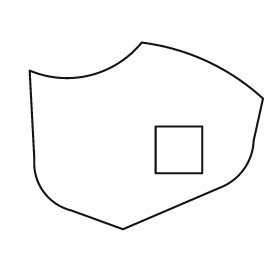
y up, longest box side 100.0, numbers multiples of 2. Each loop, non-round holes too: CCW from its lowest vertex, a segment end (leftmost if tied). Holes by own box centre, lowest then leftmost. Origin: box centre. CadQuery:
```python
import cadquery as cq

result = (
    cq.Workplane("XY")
    .moveTo(-10.0, -40.0)
    .lineTo(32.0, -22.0)
    .threePointArc((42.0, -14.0), (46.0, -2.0))
    .lineTo(50.0, 16.0)
    .threePointArc((26.0, 32.0), (-2.0, 40.0))
    .threePointArc((-24.0, 26.0), (-50.0, 28.0))
    .lineTo(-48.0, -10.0)
    .threePointArc((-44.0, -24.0), (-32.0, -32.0))
    .close()
    .moveTo(4.0, -16.0)
    .lineTo(24.0, -16.0)
    .lineTo(24.0, 4.0)
    .lineTo(4.0, 4.0)
    .close()
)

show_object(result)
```